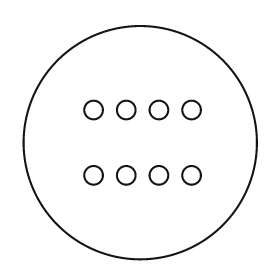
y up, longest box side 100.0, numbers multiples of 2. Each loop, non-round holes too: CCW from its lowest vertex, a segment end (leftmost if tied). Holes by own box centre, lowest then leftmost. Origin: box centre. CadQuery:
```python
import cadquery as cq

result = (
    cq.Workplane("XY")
    .moveTo(0.0, 0.0)
    .circle(50.0)
    .moveTo(-20.0, -14.0)
    .circle(4.0)
    .moveTo(-6.0, -14.0)
    .circle(4.0)
    .moveTo(8.0, -14.0)
    .circle(4.0)
    .moveTo(22.0, -14.0)
    .circle(4.0)
    .moveTo(-20.0, 14.0)
    .circle(4.0)
    .moveTo(-6.0, 14.0)
    .circle(4.0)
    .moveTo(8.0, 14.0)
    .circle(4.0)
    .moveTo(22.0, 14.0)
    .circle(4.0)
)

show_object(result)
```